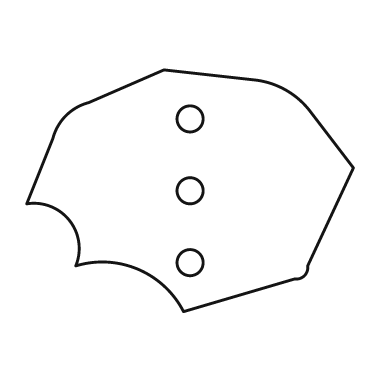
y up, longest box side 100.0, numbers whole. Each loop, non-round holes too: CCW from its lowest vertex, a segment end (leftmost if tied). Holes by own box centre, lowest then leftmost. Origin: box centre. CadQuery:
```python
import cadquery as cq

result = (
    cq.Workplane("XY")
    .moveTo(-2.0, -37.0)
    .lineTo(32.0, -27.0)
    .threePointArc((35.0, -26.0), (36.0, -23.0))
    .lineTo(50.0, 7.0)
    .lineTo(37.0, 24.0)
    .threePointArc((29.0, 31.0), (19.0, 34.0))
    .lineTo(-8.0, 37.0)
    .lineTo(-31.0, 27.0)
    .threePointArc((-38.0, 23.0), (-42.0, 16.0))
    .lineTo(-50.0, -4.0)
    .threePointArc((-37.0, -9.0), (-35.0, -23.0))
    .threePointArc((-16.0, -24.0), (-2.0, -37.0))
    .close()
    .moveTo(0.0, -22.0)
    .circle(4.0)
    .moveTo(0.0, 0.0)
    .circle(4.0)
    .moveTo(0.0, 22.0)
    .circle(4.0)
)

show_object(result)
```